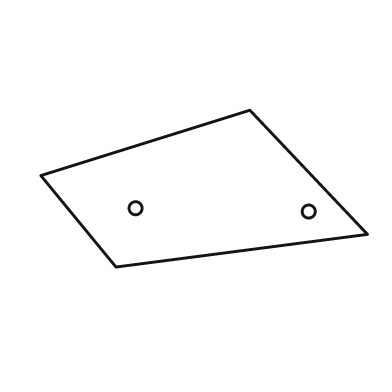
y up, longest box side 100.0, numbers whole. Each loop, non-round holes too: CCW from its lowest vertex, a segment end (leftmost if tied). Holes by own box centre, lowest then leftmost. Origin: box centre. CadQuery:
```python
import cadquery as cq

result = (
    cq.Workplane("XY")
    .moveTo(-27.0, -24.0)
    .lineTo(50.0, -14.0)
    .lineTo(14.0, 24.0)
    .lineTo(-50.0, 4.0)
    .close()
    .moveTo(32.0, -7.0)
    .circle(2.0)
    .moveTo(-21.0, -6.0)
    .circle(2.0)
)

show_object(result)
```